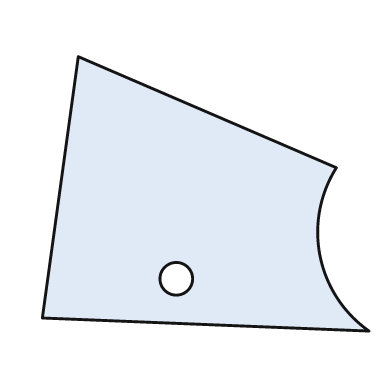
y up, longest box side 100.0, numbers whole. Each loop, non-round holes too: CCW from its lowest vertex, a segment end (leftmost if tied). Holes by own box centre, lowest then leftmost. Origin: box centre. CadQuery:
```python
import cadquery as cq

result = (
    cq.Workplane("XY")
    .moveTo(50.0, -42.0)
    .threePointArc((35.0, -19.0), (40.0, 8.0))
    .lineTo(-39.0, 42.0)
    .lineTo(-50.0, -38.0)
    .close()
    .moveTo(-9.0, -26.0)
    .circle(5.0)
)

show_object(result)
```